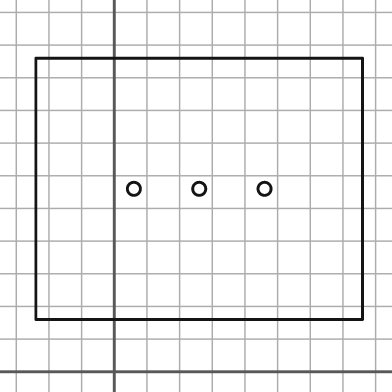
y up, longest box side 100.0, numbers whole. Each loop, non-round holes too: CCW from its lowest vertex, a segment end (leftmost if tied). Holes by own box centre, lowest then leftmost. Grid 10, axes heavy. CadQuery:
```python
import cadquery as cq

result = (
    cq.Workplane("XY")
    .moveTo(-24.0, 16.0)
    .lineTo(76.0, 16.0)
    .lineTo(76.0, 96.0)
    .lineTo(-24.0, 96.0)
    .close()
    .moveTo(6.0, 56.0)
    .circle(2.0)
    .moveTo(26.0, 56.0)
    .circle(2.0)
    .moveTo(46.0, 56.0)
    .circle(2.0)
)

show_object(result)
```